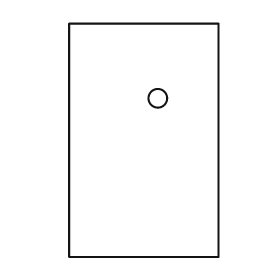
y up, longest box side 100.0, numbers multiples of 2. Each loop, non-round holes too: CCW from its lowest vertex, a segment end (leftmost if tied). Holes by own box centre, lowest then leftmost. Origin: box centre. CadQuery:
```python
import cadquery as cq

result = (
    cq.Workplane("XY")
    .moveTo(-32.0, -50.0)
    .lineTo(32.0, -50.0)
    .lineTo(32.0, 50.0)
    .lineTo(-32.0, 50.0)
    .close()
    .moveTo(6.0, 18.0)
    .circle(4.0)
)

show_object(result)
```